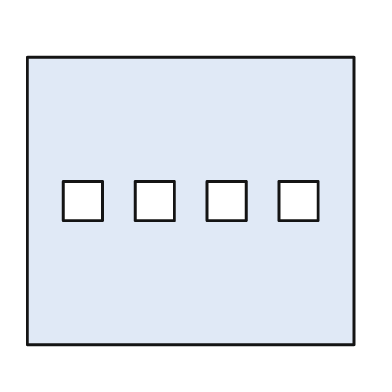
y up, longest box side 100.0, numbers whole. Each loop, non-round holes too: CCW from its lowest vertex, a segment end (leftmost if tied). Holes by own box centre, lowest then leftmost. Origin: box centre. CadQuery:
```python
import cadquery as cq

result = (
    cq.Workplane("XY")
    .moveTo(-50.0, -44.0)
    .lineTo(50.0, -44.0)
    .lineTo(50.0, 44.0)
    .lineTo(-50.0, 44.0)
    .close()
    .moveTo(-39.0, -6.0)
    .lineTo(-27.0, -6.0)
    .lineTo(-27.0, 6.0)
    .lineTo(-39.0, 6.0)
    .close()
    .moveTo(-17.0, -6.0)
    .lineTo(-5.0, -6.0)
    .lineTo(-5.0, 6.0)
    .lineTo(-17.0, 6.0)
    .close()
    .moveTo(5.0, -6.0)
    .lineTo(17.0, -6.0)
    .lineTo(17.0, 6.0)
    .lineTo(5.0, 6.0)
    .close()
    .moveTo(27.0, -6.0)
    .lineTo(39.0, -6.0)
    .lineTo(39.0, 6.0)
    .lineTo(27.0, 6.0)
    .close()
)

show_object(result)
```